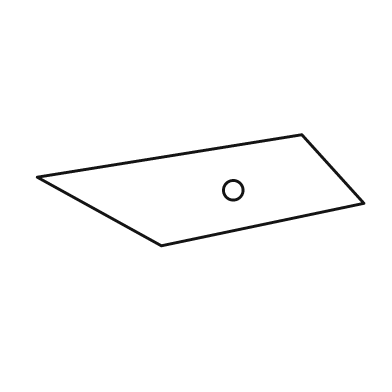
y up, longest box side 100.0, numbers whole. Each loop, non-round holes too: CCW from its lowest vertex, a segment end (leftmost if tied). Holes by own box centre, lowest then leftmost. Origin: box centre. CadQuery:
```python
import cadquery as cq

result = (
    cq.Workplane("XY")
    .moveTo(-12.0, -17.0)
    .lineTo(50.0, -4.0)
    .lineTo(31.0, 17.0)
    .lineTo(-50.0, 4.0)
    .close()
    .moveTo(10.0, 0.0)
    .circle(3.0)
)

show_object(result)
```